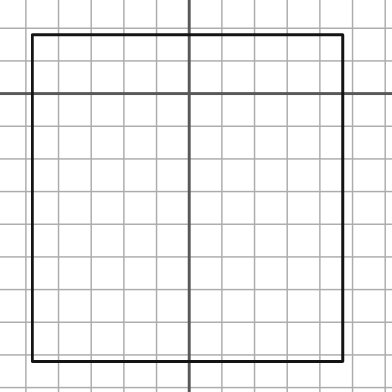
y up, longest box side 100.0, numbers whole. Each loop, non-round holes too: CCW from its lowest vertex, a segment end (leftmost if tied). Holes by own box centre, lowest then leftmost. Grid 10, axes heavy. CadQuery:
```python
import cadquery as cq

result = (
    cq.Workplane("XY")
    .moveTo(-48.0, -82.0)
    .lineTo(47.0, -82.0)
    .lineTo(47.0, 18.0)
    .lineTo(-48.0, 18.0)
    .close()
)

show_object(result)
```